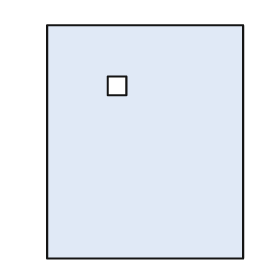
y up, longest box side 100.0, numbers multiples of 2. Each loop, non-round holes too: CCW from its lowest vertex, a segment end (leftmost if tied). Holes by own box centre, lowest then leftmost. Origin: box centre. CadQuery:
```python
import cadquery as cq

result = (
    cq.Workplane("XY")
    .moveTo(-42.0, -50.0)
    .lineTo(42.0, -50.0)
    .lineTo(42.0, 50.0)
    .lineTo(-42.0, 50.0)
    .close()
    .moveTo(-16.0, 20.0)
    .lineTo(-8.0, 20.0)
    .lineTo(-8.0, 28.0)
    .lineTo(-16.0, 28.0)
    .close()
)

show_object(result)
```